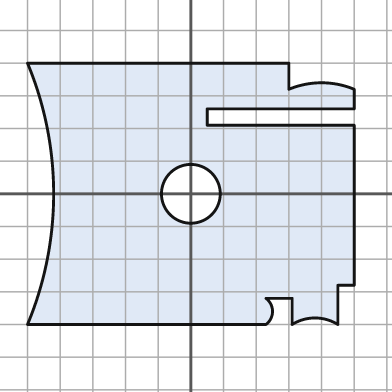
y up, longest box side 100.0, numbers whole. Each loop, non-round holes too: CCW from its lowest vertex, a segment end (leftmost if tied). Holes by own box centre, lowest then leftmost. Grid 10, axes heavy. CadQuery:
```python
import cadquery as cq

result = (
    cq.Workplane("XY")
    .moveTo(-50.0, -40.0)
    .lineTo(23.0, -40.0)
    .threePointArc((25.0, -36.0), (23.0, -32.0))
    .lineTo(31.0, -32.0)
    .lineTo(31.0, -40.0)
    .threePointArc((38.0, -38.0), (45.0, -40.0))
    .lineTo(45.0, -28.0)
    .lineTo(50.0, -28.0)
    .lineTo(50.0, 21.0)
    .lineTo(5.0, 21.0)
    .lineTo(5.0, 26.0)
    .lineTo(50.0, 26.0)
    .lineTo(50.0, 32.0)
    .threePointArc((40.0, 34.0), (30.0, 32.0))
    .lineTo(30.0, 40.0)
    .lineTo(-50.0, 40.0)
    .threePointArc((-42.0, 0.0), (-50.0, -40.0))
    .close()
    .moveTo(0.0, 0.0)
    .circle(9.0)
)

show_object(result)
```